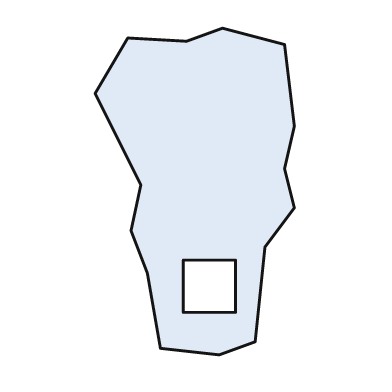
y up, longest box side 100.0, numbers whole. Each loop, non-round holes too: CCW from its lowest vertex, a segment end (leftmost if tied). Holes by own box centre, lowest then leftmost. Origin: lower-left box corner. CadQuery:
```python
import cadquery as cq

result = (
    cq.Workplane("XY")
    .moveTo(38.0, 0.0)
    .lineTo(49.0, 4.0)
    .lineTo(52.0, 33.0)
    .lineTo(61.0, 45.0)
    .lineTo(58.0, 57.0)
    .lineTo(61.0, 70.0)
    .lineTo(58.0, 95.0)
    .lineTo(39.0, 100.0)
    .lineTo(28.0, 96.0)
    .lineTo(10.0, 97.0)
    .lineTo(0.0, 80.0)
    .lineTo(14.0, 52.0)
    .lineTo(11.0, 38.0)
    .lineTo(16.0, 25.0)
    .lineTo(20.0, 2.0)
    .close()
    .moveTo(27.0, 13.0)
    .lineTo(43.0, 13.0)
    .lineTo(43.0, 29.0)
    .lineTo(27.0, 29.0)
    .close()
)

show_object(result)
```